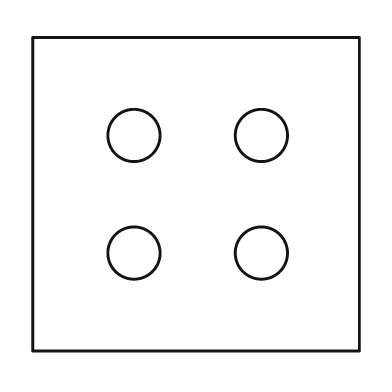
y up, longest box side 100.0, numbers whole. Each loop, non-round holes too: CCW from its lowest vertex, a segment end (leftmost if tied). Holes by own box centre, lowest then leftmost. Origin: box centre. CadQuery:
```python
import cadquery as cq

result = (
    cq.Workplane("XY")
    .moveTo(-50.0, -48.0)
    .lineTo(50.0, -48.0)
    .lineTo(50.0, 48.0)
    .lineTo(-50.0, 48.0)
    .close()
    .moveTo(-19.0, -18.0)
    .circle(8.0)
    .moveTo(20.0, -18.0)
    .circle(8.0)
    .moveTo(-19.0, 18.0)
    .circle(8.0)
    .moveTo(20.0, 18.0)
    .circle(8.0)
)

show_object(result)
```